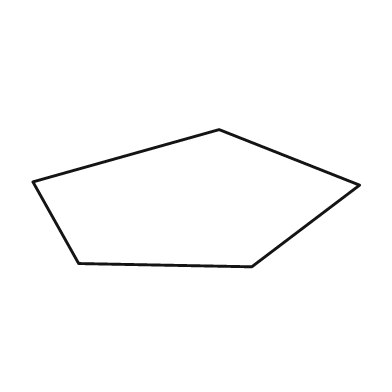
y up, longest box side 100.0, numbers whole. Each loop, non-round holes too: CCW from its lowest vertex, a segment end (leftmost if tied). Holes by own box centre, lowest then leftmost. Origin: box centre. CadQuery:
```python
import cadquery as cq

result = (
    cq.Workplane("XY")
    .moveTo(17.0, -21.0)
    .lineTo(50.0, 4.0)
    .lineTo(7.0, 21.0)
    .lineTo(-50.0, 5.0)
    .lineTo(-36.0, -20.0)
    .close()
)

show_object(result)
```